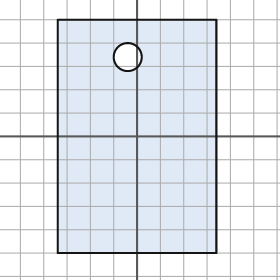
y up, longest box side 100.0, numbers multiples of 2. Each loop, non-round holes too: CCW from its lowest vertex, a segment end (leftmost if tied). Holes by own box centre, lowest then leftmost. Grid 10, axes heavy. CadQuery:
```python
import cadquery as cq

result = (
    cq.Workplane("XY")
    .moveTo(-34.0, -50.0)
    .lineTo(34.0, -50.0)
    .lineTo(34.0, 50.0)
    .lineTo(-34.0, 50.0)
    .close()
    .moveTo(-4.0, 34.0)
    .circle(6.0)
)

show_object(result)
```